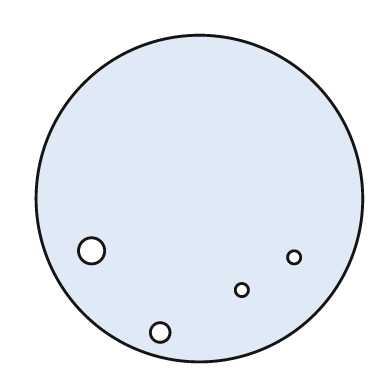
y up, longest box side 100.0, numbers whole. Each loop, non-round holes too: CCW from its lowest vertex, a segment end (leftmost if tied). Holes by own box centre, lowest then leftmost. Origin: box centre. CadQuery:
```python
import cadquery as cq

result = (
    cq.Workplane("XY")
    .moveTo(0.0, 0.0)
    .circle(50.0)
    .moveTo(-12.0, -41.0)
    .circle(3.0)
    .moveTo(13.0, -28.0)
    .circle(2.0)
    .moveTo(29.0, -18.0)
    .circle(2.0)
    .moveTo(-33.0, -16.0)
    .circle(4.0)
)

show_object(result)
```